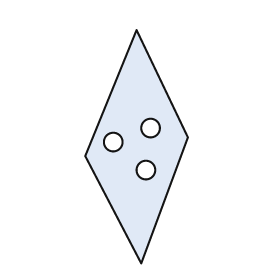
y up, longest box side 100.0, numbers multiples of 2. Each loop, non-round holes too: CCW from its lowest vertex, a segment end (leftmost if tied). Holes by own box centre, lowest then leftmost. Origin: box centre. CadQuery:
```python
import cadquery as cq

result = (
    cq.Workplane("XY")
    .moveTo(2.0, -50.0)
    .lineTo(22.0, 4.0)
    .lineTo(0.0, 50.0)
    .lineTo(-22.0, -4.0)
    .close()
    .moveTo(4.0, -10.0)
    .circle(4.0)
    .moveTo(-10.0, 2.0)
    .circle(4.0)
    .moveTo(6.0, 8.0)
    .circle(4.0)
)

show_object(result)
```